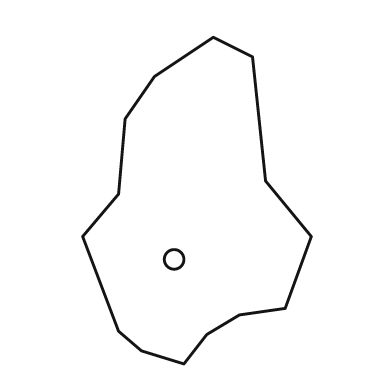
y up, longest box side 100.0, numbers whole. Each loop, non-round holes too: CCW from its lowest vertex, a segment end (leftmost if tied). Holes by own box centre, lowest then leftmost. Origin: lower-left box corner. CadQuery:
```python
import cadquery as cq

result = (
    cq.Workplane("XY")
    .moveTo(31.0, 0.0)
    .lineTo(38.0, 9.0)
    .lineTo(48.0, 15.0)
    .lineTo(62.0, 17.0)
    .lineTo(70.0, 39.0)
    .lineTo(56.0, 56.0)
    .lineTo(52.0, 94.0)
    .lineTo(40.0, 100.0)
    .lineTo(22.0, 88.0)
    .lineTo(13.0, 75.0)
    .lineTo(11.0, 52.0)
    .lineTo(0.0, 39.0)
    .lineTo(11.0, 10.0)
    .lineTo(18.0, 4.0)
    .close()
    .moveTo(28.0, 32.0)
    .circle(3.0)
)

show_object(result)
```